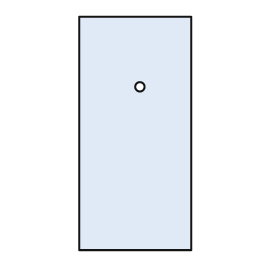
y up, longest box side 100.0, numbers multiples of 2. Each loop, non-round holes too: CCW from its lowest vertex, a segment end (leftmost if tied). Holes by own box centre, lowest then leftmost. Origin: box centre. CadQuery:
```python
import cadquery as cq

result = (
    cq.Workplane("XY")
    .moveTo(-24.0, -50.0)
    .lineTo(24.0, -50.0)
    .lineTo(24.0, 50.0)
    .lineTo(-24.0, 50.0)
    .close()
    .moveTo(2.0, 20.0)
    .circle(2.0)
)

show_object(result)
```